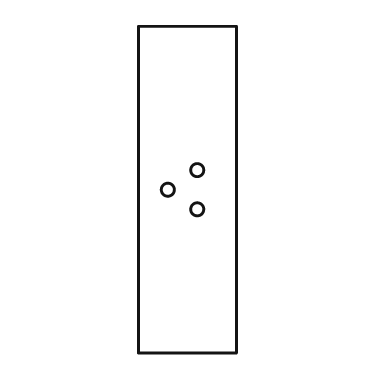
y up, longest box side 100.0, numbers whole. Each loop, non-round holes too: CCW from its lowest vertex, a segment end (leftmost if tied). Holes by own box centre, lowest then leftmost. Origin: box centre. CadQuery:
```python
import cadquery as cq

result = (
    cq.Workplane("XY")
    .moveTo(-15.0, -50.0)
    .lineTo(15.0, -50.0)
    .lineTo(15.0, 50.0)
    .lineTo(-15.0, 50.0)
    .close()
    .moveTo(3.0, -6.0)
    .circle(2.0)
    .moveTo(-6.0, 0.0)
    .circle(2.0)
    .moveTo(3.0, 6.0)
    .circle(2.0)
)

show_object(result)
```